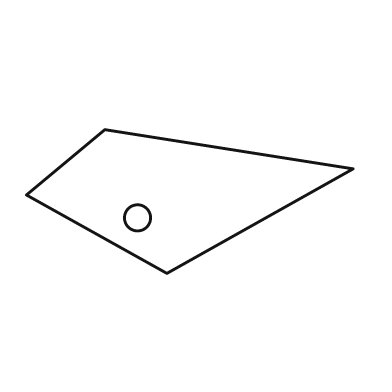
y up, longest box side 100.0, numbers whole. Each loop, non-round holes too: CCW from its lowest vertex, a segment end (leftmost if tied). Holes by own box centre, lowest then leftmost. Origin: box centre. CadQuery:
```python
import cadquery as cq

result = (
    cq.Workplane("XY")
    .moveTo(-7.0, -22.0)
    .lineTo(50.0, 10.0)
    .lineTo(-26.0, 22.0)
    .lineTo(-50.0, 2.0)
    .close()
    .moveTo(-16.0, -5.0)
    .circle(4.0)
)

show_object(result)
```